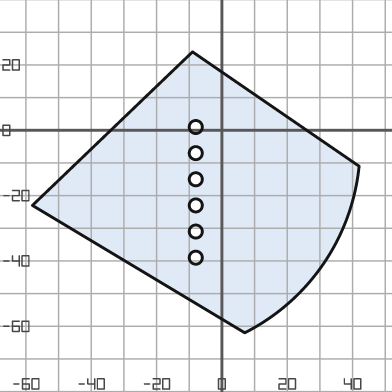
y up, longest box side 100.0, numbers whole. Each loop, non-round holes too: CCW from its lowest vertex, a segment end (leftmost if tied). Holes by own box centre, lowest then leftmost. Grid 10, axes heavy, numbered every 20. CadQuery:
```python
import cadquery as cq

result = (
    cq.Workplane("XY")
    .moveTo(7.0, -62.0)
    .threePointArc((31.0, -41.0), (42.0, -11.0))
    .lineTo(-9.0, 24.0)
    .lineTo(-58.0, -23.0)
    .close()
    .moveTo(-8.0, -39.0)
    .circle(2.0)
    .moveTo(-8.0, -31.0)
    .circle(2.0)
    .moveTo(-8.0, -23.0)
    .circle(2.0)
    .moveTo(-8.0, -15.0)
    .circle(2.0)
    .moveTo(-8.0, -7.0)
    .circle(2.0)
    .moveTo(-8.0, 1.0)
    .circle(2.0)
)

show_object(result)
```